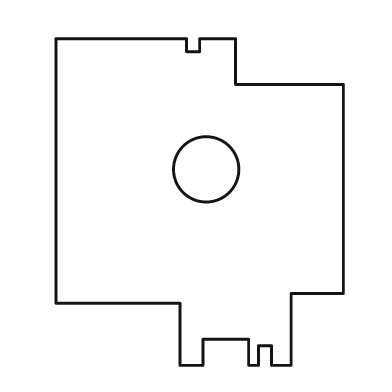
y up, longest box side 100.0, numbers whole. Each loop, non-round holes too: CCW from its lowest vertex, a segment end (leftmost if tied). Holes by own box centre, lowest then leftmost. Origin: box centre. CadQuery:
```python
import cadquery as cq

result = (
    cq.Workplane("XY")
    .moveTo(-6.0, -50.0)
    .lineTo(1.0, -50.0)
    .lineTo(1.0, -42.0)
    .lineTo(15.0, -42.0)
    .lineTo(15.0, -50.0)
    .lineTo(18.0, -50.0)
    .lineTo(18.0, -44.0)
    .lineTo(22.0, -44.0)
    .lineTo(22.0, -50.0)
    .lineTo(28.0, -50.0)
    .lineTo(28.0, -28.0)
    .lineTo(44.0, -28.0)
    .lineTo(44.0, 36.0)
    .lineTo(11.0, 36.0)
    .lineTo(11.0, 50.0)
    .lineTo(0.0, 50.0)
    .lineTo(0.0, 46.0)
    .lineTo(-4.0, 46.0)
    .lineTo(-4.0, 50.0)
    .lineTo(-44.0, 50.0)
    .lineTo(-44.0, -31.0)
    .lineTo(-6.0, -31.0)
    .close()
    .moveTo(2.0, 10.0)
    .circle(10.0)
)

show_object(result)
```